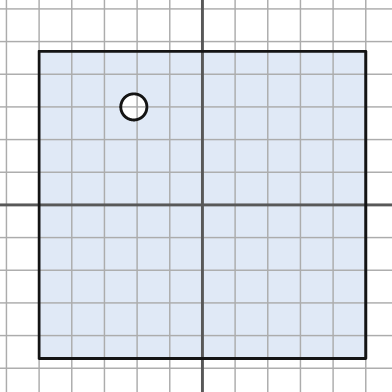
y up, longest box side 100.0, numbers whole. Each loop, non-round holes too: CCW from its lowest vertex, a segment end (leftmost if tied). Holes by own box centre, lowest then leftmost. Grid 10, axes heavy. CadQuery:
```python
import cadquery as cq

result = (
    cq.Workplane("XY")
    .moveTo(-50.0, -47.0)
    .lineTo(50.0, -47.0)
    .lineTo(50.0, 47.0)
    .lineTo(-50.0, 47.0)
    .close()
    .moveTo(-21.0, 30.0)
    .circle(4.0)
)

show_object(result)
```